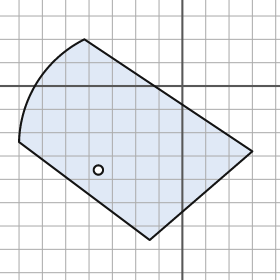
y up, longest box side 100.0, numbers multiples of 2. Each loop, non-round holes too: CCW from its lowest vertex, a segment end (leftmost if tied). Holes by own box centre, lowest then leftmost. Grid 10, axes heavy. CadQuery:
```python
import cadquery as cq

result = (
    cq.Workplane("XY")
    .moveTo(-14.0, -66.0)
    .lineTo(30.0, -28.0)
    .lineTo(-42.0, 20.0)
    .threePointArc((-62.0, 2.0), (-70.0, -24.0))
    .close()
    .moveTo(-36.0, -36.0)
    .circle(2.0)
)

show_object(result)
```